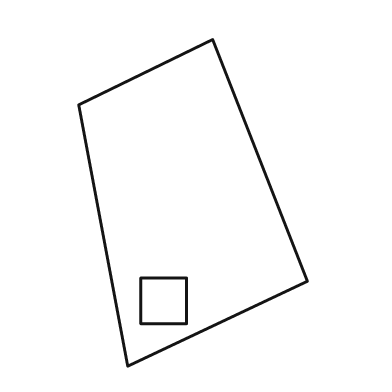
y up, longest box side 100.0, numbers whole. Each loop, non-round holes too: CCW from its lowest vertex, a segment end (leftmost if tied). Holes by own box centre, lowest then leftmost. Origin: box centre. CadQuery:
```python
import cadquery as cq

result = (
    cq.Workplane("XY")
    .moveTo(-20.0, -50.0)
    .lineTo(35.0, -24.0)
    .lineTo(6.0, 50.0)
    .lineTo(-35.0, 30.0)
    .close()
    .moveTo(-16.0, -37.0)
    .lineTo(-2.0, -37.0)
    .lineTo(-2.0, -23.0)
    .lineTo(-16.0, -23.0)
    .close()
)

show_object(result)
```